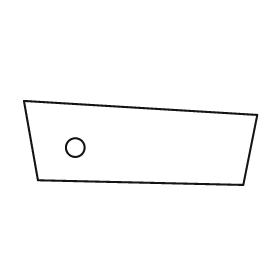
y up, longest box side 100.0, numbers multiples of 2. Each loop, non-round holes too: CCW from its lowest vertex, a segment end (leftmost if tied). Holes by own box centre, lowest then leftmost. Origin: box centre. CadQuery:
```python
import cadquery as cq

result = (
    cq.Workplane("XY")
    .moveTo(44.0, -18.0)
    .lineTo(50.0, 12.0)
    .lineTo(-50.0, 18.0)
    .lineTo(-44.0, -16.0)
    .close()
    .moveTo(-28.0, -2.0)
    .circle(4.0)
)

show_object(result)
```